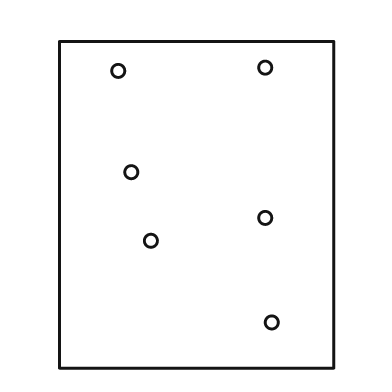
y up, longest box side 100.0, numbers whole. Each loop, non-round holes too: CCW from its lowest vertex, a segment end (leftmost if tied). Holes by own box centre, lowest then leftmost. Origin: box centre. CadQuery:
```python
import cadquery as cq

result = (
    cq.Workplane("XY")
    .moveTo(-42.0, -50.0)
    .lineTo(42.0, -50.0)
    .lineTo(42.0, 50.0)
    .lineTo(-42.0, 50.0)
    .close()
    .moveTo(23.0, -36.0)
    .circle(2.0)
    .moveTo(-14.0, -11.0)
    .circle(2.0)
    .moveTo(21.0, -4.0)
    .circle(2.0)
    .moveTo(-20.0, 10.0)
    .circle(2.0)
    .moveTo(-24.0, 41.0)
    .circle(2.0)
    .moveTo(21.0, 42.0)
    .circle(2.0)
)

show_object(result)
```